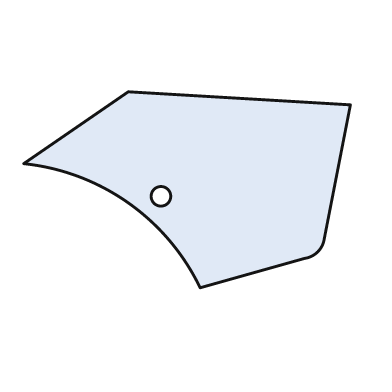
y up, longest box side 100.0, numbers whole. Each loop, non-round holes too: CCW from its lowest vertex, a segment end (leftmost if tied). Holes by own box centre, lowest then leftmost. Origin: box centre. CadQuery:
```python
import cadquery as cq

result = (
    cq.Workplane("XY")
    .moveTo(4.0, -30.0)
    .lineTo(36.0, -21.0)
    .threePointArc((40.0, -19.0), (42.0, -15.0))
    .lineTo(50.0, 26.0)
    .lineTo(-18.0, 30.0)
    .lineTo(-50.0, 8.0)
    .threePointArc((-18.0, -4.0), (4.0, -30.0))
    .close()
    .moveTo(-8.0, -2.0)
    .circle(3.0)
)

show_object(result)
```